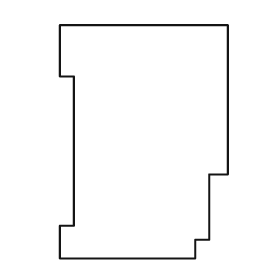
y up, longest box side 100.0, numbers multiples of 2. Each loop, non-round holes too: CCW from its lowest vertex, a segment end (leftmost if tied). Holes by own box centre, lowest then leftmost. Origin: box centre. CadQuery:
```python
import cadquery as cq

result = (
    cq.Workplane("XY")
    .moveTo(-36.0, -50.0)
    .lineTo(22.0, -50.0)
    .lineTo(22.0, -42.0)
    .lineTo(28.0, -42.0)
    .lineTo(28.0, -14.0)
    .lineTo(36.0, -14.0)
    .lineTo(36.0, 50.0)
    .lineTo(-36.0, 50.0)
    .lineTo(-36.0, 28.0)
    .lineTo(-30.0, 28.0)
    .lineTo(-30.0, -36.0)
    .lineTo(-36.0, -36.0)
    .close()
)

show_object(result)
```